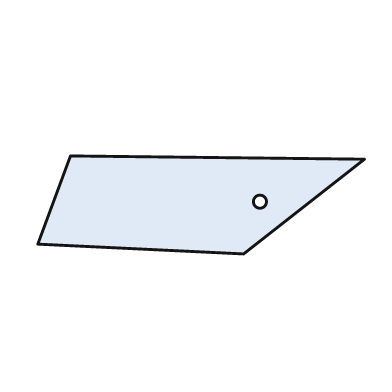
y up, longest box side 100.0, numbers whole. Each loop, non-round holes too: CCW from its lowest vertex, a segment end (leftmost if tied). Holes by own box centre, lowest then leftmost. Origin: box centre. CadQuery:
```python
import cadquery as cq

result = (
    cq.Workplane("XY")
    .moveTo(13.0, -15.0)
    .lineTo(50.0, 14.0)
    .lineTo(-40.0, 15.0)
    .lineTo(-50.0, -12.0)
    .close()
    .moveTo(18.0, 1.0)
    .circle(2.0)
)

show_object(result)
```